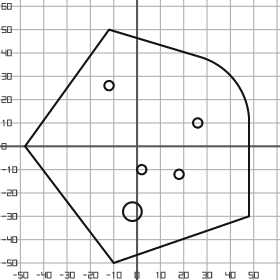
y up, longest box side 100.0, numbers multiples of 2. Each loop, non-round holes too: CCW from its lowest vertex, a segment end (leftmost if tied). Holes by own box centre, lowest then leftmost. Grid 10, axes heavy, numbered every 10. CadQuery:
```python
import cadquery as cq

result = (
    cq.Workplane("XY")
    .moveTo(-10.0, -50.0)
    .lineTo(48.0, -30.0)
    .lineTo(48.0, 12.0)
    .threePointArc((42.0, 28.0), (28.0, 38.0))
    .lineTo(-12.0, 50.0)
    .lineTo(-48.0, 0.0)
    .close()
    .moveTo(-2.0, -28.0)
    .circle(4.0)
    .moveTo(18.0, -12.0)
    .circle(2.0)
    .moveTo(2.0, -10.0)
    .circle(2.0)
    .moveTo(26.0, 10.0)
    .circle(2.0)
    .moveTo(-12.0, 26.0)
    .circle(2.0)
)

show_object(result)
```